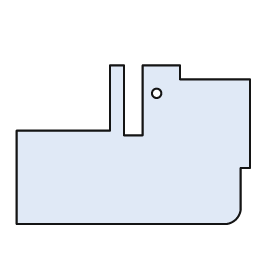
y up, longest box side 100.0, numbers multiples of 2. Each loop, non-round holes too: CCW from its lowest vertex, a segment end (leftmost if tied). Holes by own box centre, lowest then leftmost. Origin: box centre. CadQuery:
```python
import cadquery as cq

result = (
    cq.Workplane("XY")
    .moveTo(-50.0, -34.0)
    .lineTo(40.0, -34.0)
    .threePointArc((44.0, -32.0), (46.0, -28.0))
    .lineTo(46.0, -10.0)
    .lineTo(50.0, -10.0)
    .lineTo(50.0, 28.0)
    .lineTo(20.0, 28.0)
    .lineTo(20.0, 34.0)
    .lineTo(4.0, 34.0)
    .lineTo(4.0, 4.0)
    .lineTo(-4.0, 4.0)
    .lineTo(-4.0, 34.0)
    .lineTo(-10.0, 34.0)
    .lineTo(-10.0, 6.0)
    .lineTo(-50.0, 6.0)
    .close()
    .moveTo(10.0, 22.0)
    .circle(2.0)
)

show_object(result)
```